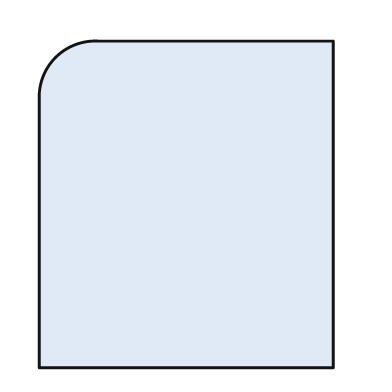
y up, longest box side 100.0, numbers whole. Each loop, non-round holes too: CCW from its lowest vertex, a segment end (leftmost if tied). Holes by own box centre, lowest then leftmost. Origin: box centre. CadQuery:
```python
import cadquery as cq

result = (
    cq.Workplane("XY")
    .moveTo(-45.0, -50.0)
    .lineTo(45.0, -50.0)
    .lineTo(45.0, 50.0)
    .lineTo(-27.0, 50.0)
    .threePointArc((-40.0, 45.0), (-45.0, 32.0))
    .close()
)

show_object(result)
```